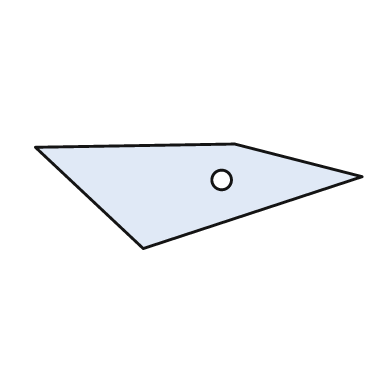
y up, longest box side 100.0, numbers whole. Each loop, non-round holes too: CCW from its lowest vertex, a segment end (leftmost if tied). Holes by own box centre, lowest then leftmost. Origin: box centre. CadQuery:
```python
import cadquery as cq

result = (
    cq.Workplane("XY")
    .moveTo(-17.0, -16.0)
    .lineTo(50.0, 6.0)
    .lineTo(11.0, 16.0)
    .lineTo(-50.0, 15.0)
    .close()
    .moveTo(7.0, 5.0)
    .circle(3.0)
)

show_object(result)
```